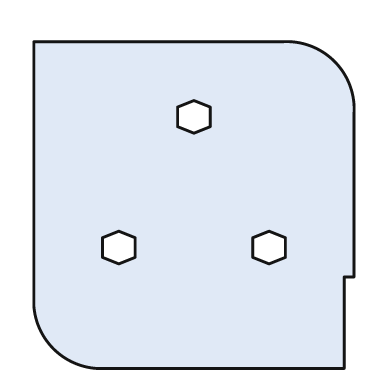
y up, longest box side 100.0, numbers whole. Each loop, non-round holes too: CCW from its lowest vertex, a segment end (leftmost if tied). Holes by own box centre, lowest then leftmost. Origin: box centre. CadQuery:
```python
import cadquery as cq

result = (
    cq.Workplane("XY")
    .moveTo(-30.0, -50.0)
    .lineTo(46.0, -50.0)
    .lineTo(46.0, -22.0)
    .lineTo(49.0, -22.0)
    .lineTo(49.0, 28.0)
    .threePointArc((43.0, 44.0), (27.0, 50.0))
    .lineTo(-49.0, 50.0)
    .lineTo(-49.0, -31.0)
    .threePointArc((-43.0, -44.0), (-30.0, -50.0))
    .close()
    .moveTo(-23.0, -18.0)
    .lineTo(-18.0, -16.0)
    .lineTo(-18.0, -10.0)
    .lineTo(-23.0, -8.0)
    .lineTo(-28.0, -10.0)
    .lineTo(-28.0, -16.0)
    .close()
    .moveTo(23.0, -18.0)
    .lineTo(28.0, -16.0)
    .lineTo(28.0, -10.0)
    .lineTo(23.0, -8.0)
    .lineTo(18.0, -10.0)
    .lineTo(18.0, -16.0)
    .close()
    .moveTo(0.0, 22.0)
    .lineTo(5.0, 24.0)
    .lineTo(5.0, 30.0)
    .lineTo(0.0, 32.0)
    .lineTo(-5.0, 30.0)
    .lineTo(-5.0, 24.0)
    .close()
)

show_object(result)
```